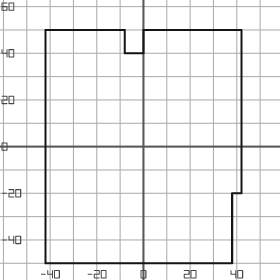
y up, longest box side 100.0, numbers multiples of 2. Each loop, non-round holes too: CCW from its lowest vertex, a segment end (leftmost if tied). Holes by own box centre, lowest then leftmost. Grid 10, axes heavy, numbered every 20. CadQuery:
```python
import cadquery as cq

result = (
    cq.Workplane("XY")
    .moveTo(-42.0, -50.0)
    .lineTo(38.0, -50.0)
    .lineTo(38.0, -20.0)
    .lineTo(42.0, -20.0)
    .lineTo(42.0, 50.0)
    .lineTo(0.0, 50.0)
    .lineTo(0.0, 40.0)
    .lineTo(-8.0, 40.0)
    .lineTo(-8.0, 50.0)
    .lineTo(-42.0, 50.0)
    .close()
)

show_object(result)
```